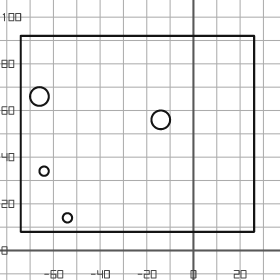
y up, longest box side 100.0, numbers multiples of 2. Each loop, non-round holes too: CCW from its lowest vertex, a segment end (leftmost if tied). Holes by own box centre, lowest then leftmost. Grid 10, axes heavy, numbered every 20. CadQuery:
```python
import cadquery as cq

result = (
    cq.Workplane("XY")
    .moveTo(-74.0, 8.0)
    .lineTo(26.0, 8.0)
    .lineTo(26.0, 92.0)
    .lineTo(-74.0, 92.0)
    .close()
    .moveTo(-54.0, 14.0)
    .circle(2.0)
    .moveTo(-64.0, 34.0)
    .circle(2.0)
    .moveTo(-14.0, 56.0)
    .circle(4.0)
    .moveTo(-66.0, 66.0)
    .circle(4.0)
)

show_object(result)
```